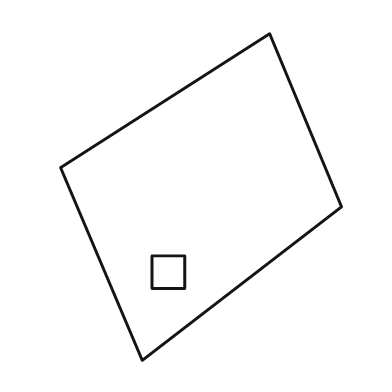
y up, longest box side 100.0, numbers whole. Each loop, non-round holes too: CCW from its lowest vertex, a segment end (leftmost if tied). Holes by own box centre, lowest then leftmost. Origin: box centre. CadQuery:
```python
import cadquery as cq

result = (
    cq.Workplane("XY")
    .moveTo(-18.0, -50.0)
    .lineTo(43.0, -3.0)
    .lineTo(21.0, 50.0)
    .lineTo(-43.0, 9.0)
    .close()
    .moveTo(-15.0, -28.0)
    .lineTo(-5.0, -28.0)
    .lineTo(-5.0, -18.0)
    .lineTo(-15.0, -18.0)
    .close()
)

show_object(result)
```